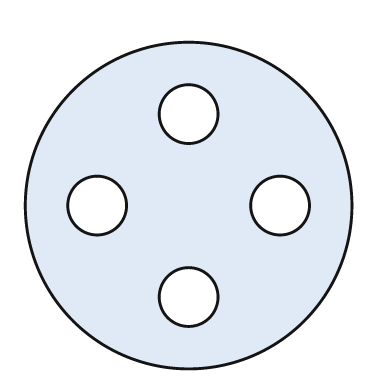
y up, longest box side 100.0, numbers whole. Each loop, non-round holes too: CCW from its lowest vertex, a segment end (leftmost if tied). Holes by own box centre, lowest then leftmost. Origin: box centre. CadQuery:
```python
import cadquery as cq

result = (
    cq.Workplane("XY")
    .moveTo(0.0, 0.0)
    .circle(50.0)
    .moveTo(0.0, -28.0)
    .circle(9.0)
    .moveTo(-28.0, 0.0)
    .circle(9.0)
    .moveTo(28.0, 0.0)
    .circle(9.0)
    .moveTo(0.0, 28.0)
    .circle(9.0)
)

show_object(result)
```